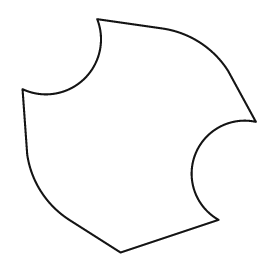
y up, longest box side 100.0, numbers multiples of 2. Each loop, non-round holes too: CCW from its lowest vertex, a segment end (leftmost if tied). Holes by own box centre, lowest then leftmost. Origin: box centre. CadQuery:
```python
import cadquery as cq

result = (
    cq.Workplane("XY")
    .moveTo(-8.0, -50.0)
    .lineTo(34.0, -36.0)
    .threePointArc((24.0, -8.0), (50.0, 6.0))
    .lineTo(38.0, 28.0)
    .threePointArc((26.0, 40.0), (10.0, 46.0))
    .lineTo(-18.0, 50.0)
    .threePointArc((-24.0, 24.0), (-50.0, 20.0))
    .lineTo(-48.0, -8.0)
    .threePointArc((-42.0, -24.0), (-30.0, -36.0))
    .close()
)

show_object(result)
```